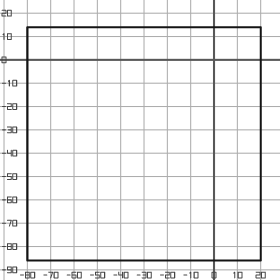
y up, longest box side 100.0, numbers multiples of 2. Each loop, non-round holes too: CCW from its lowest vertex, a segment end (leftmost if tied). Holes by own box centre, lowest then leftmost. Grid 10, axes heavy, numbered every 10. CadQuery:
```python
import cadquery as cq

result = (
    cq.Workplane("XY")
    .moveTo(-80.0, -86.0)
    .lineTo(20.0, -86.0)
    .lineTo(20.0, 14.0)
    .lineTo(-80.0, 14.0)
    .close()
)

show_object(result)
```